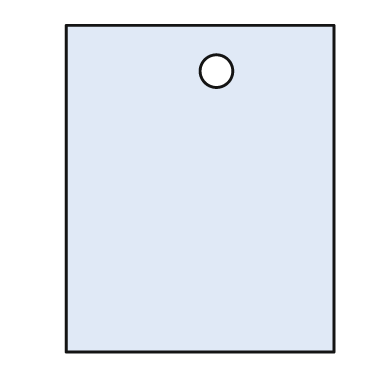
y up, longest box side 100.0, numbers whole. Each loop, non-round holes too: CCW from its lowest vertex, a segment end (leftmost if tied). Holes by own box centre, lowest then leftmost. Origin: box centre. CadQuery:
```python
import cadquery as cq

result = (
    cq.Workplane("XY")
    .moveTo(-41.0, -50.0)
    .lineTo(41.0, -50.0)
    .lineTo(41.0, 50.0)
    .lineTo(-41.0, 50.0)
    .close()
    .moveTo(5.0, 36.0)
    .circle(5.0)
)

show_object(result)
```